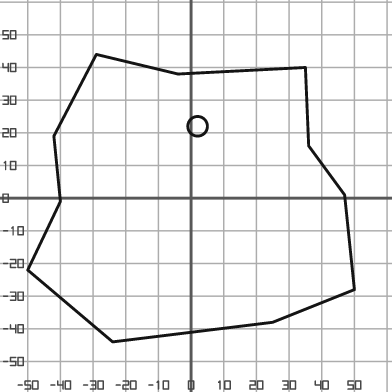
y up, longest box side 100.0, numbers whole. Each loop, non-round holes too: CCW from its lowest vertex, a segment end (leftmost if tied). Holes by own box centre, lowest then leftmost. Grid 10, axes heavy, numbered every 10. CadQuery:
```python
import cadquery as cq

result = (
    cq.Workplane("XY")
    .moveTo(-24.0, -44.0)
    .lineTo(25.0, -38.0)
    .lineTo(50.0, -28.0)
    .lineTo(47.0, 1.0)
    .lineTo(36.0, 16.0)
    .lineTo(35.0, 40.0)
    .lineTo(-4.0, 38.0)
    .lineTo(-29.0, 44.0)
    .lineTo(-42.0, 19.0)
    .lineTo(-40.0, -1.0)
    .lineTo(-50.0, -22.0)
    .close()
    .moveTo(2.0, 22.0)
    .circle(3.0)
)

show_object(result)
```